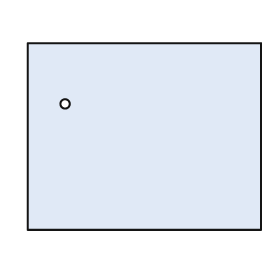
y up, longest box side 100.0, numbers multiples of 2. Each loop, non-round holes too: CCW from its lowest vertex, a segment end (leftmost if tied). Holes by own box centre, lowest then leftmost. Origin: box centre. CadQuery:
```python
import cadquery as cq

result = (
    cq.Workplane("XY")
    .moveTo(-50.0, -40.0)
    .lineTo(50.0, -40.0)
    .lineTo(50.0, 40.0)
    .lineTo(-50.0, 40.0)
    .close()
    .moveTo(-34.0, 14.0)
    .circle(2.0)
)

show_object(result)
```